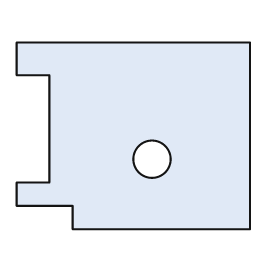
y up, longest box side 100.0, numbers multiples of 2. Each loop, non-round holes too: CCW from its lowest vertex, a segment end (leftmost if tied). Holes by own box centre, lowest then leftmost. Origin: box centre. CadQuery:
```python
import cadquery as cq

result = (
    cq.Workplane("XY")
    .moveTo(-26.0, -40.0)
    .lineTo(50.0, -40.0)
    .lineTo(50.0, 40.0)
    .lineTo(-50.0, 40.0)
    .lineTo(-50.0, 26.0)
    .lineTo(-36.0, 26.0)
    .lineTo(-36.0, -20.0)
    .lineTo(-50.0, -20.0)
    .lineTo(-50.0, -30.0)
    .lineTo(-26.0, -30.0)
    .close()
    .moveTo(8.0, -10.0)
    .circle(8.0)
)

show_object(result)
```